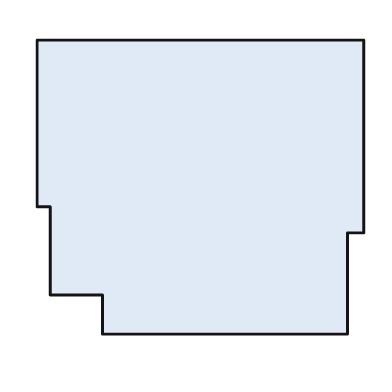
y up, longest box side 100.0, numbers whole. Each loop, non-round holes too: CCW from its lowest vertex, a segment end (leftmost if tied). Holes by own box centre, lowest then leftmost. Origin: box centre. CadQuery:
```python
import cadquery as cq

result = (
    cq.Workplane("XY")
    .moveTo(-30.0, -45.0)
    .lineTo(45.0, -45.0)
    .lineTo(45.0, -14.0)
    .lineTo(50.0, -14.0)
    .lineTo(50.0, 45.0)
    .lineTo(-50.0, 45.0)
    .lineTo(-50.0, -6.0)
    .lineTo(-46.0, -6.0)
    .lineTo(-46.0, -33.0)
    .lineTo(-30.0, -33.0)
    .close()
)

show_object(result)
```